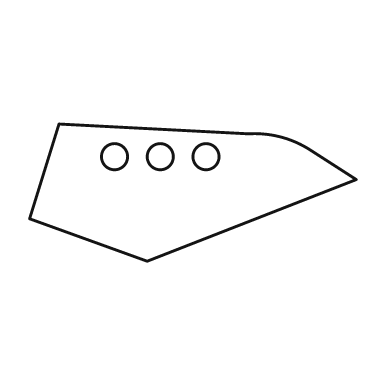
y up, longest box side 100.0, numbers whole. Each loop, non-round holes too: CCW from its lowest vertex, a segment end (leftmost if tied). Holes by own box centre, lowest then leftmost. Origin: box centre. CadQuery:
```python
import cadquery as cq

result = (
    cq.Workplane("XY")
    .moveTo(-14.0, -21.0)
    .lineTo(50.0, 4.0)
    .lineTo(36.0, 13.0)
    .threePointArc((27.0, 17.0), (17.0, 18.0))
    .lineTo(-41.0, 21.0)
    .lineTo(-50.0, -8.0)
    .close()
    .moveTo(-24.0, 11.0)
    .circle(4.0)
    .moveTo(-10.0, 11.0)
    .circle(4.0)
    .moveTo(4.0, 11.0)
    .circle(4.0)
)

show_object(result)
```